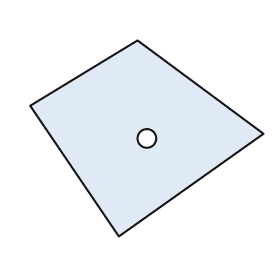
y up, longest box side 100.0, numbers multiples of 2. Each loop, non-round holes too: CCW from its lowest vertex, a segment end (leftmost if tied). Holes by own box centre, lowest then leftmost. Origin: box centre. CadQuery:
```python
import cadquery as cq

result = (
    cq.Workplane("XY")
    .moveTo(-12.0, -42.0)
    .lineTo(50.0, 2.0)
    .lineTo(-4.0, 42.0)
    .lineTo(-50.0, 14.0)
    .close()
    .moveTo(0.0, 0.0)
    .circle(4.0)
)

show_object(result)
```